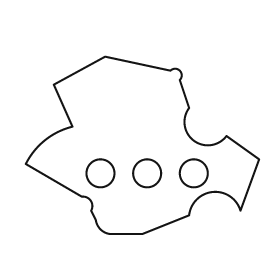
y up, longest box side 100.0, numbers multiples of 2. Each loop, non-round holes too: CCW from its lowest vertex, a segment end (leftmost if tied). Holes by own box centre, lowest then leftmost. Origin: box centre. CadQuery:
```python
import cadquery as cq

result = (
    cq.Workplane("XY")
    .moveTo(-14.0, -38.0)
    .lineTo(0.0, -38.0)
    .lineTo(20.0, -30.0)
    .threePointArc((30.0, -20.0), (42.0, -28.0))
    .lineTo(50.0, -6.0)
    .lineTo(36.0, 4.0)
    .threePointArc((22.0, 2.0), (20.0, 16.0))
    .lineTo(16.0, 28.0)
    .threePointArc((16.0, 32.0), (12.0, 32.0))
    .lineTo(-16.0, 38.0)
    .lineTo(-38.0, 26.0)
    .lineTo(-30.0, 8.0)
    .threePointArc((-42.0, 2.0), (-50.0, -8.0))
    .lineTo(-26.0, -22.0)
    .threePointArc((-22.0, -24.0), (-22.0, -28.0))
    .lineTo(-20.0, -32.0)
    .threePointArc((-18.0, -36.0), (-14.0, -38.0))
    .close()
    .moveTo(-18.0, -12.0)
    .circle(6.0)
    .moveTo(2.0, -12.0)
    .circle(6.0)
    .moveTo(22.0, -12.0)
    .circle(6.0)
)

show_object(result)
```